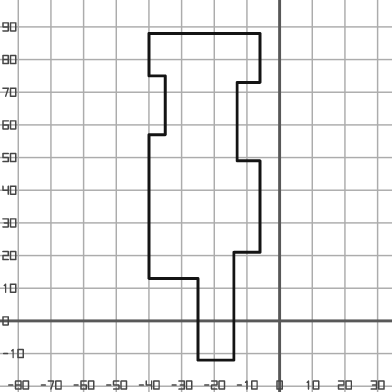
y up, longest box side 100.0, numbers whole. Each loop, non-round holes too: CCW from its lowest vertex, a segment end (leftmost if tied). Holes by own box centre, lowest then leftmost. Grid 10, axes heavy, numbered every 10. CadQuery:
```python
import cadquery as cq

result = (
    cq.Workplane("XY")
    .moveTo(-25.0, -12.0)
    .lineTo(-14.0, -12.0)
    .lineTo(-14.0, 21.0)
    .lineTo(-6.0, 21.0)
    .lineTo(-6.0, 49.0)
    .lineTo(-13.0, 49.0)
    .lineTo(-13.0, 73.0)
    .lineTo(-6.0, 73.0)
    .lineTo(-6.0, 88.0)
    .lineTo(-40.0, 88.0)
    .lineTo(-40.0, 75.0)
    .lineTo(-35.0, 75.0)
    .lineTo(-35.0, 57.0)
    .lineTo(-40.0, 57.0)
    .lineTo(-40.0, 13.0)
    .lineTo(-25.0, 13.0)
    .close()
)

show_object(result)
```